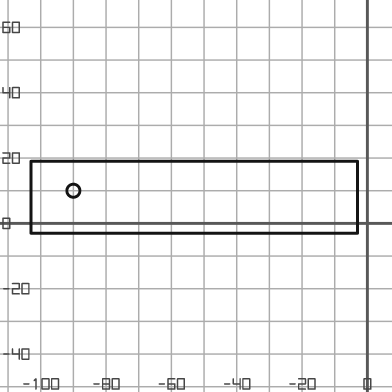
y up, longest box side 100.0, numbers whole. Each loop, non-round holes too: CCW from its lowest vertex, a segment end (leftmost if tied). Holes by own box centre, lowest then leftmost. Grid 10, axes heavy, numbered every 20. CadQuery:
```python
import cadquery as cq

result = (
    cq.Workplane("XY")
    .moveTo(-103.0, -3.0)
    .lineTo(-3.0, -3.0)
    .lineTo(-3.0, 19.0)
    .lineTo(-103.0, 19.0)
    .close()
    .moveTo(-90.0, 10.0)
    .circle(2.0)
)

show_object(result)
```